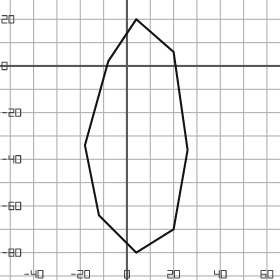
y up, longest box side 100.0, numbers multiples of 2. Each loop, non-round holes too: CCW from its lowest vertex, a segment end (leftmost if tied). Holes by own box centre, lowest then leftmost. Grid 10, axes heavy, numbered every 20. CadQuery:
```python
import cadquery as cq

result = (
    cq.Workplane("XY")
    .moveTo(4.0, -80.0)
    .lineTo(20.0, -70.0)
    .lineTo(26.0, -36.0)
    .lineTo(20.0, 6.0)
    .lineTo(4.0, 20.0)
    .lineTo(-8.0, 2.0)
    .lineTo(-18.0, -34.0)
    .lineTo(-12.0, -64.0)
    .close()
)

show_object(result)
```